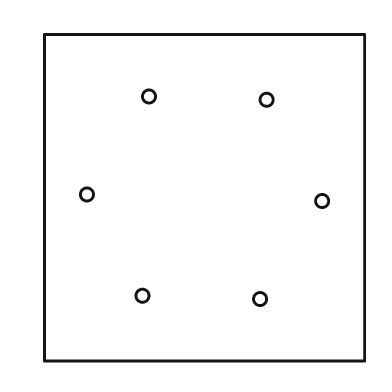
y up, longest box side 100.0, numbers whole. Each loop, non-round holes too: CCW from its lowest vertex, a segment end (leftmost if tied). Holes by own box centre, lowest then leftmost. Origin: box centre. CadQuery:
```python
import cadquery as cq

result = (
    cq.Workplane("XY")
    .moveTo(-49.0, -50.0)
    .lineTo(49.0, -50.0)
    .lineTo(49.0, 50.0)
    .lineTo(-49.0, 50.0)
    .close()
    .moveTo(17.0, -31.0)
    .circle(2.0)
    .moveTo(-19.0, -30.0)
    .circle(2.0)
    .moveTo(36.0, -1.0)
    .circle(2.0)
    .moveTo(-36.0, 1.0)
    .circle(2.0)
    .moveTo(19.0, 30.0)
    .circle(2.0)
    .moveTo(-17.0, 31.0)
    .circle(2.0)
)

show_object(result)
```